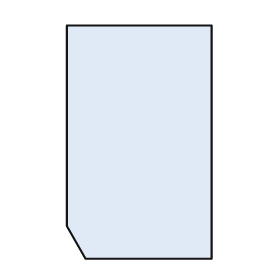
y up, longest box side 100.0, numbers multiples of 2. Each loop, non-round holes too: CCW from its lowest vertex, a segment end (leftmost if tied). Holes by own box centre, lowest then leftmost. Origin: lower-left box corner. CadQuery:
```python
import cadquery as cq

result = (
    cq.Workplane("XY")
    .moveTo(8.0, 0.0)
    .lineTo(62.0, 0.0)
    .lineTo(62.0, 100.0)
    .lineTo(0.0, 100.0)
    .lineTo(0.0, 14.0)
    .close()
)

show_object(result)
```